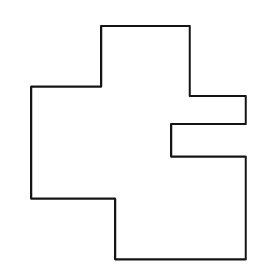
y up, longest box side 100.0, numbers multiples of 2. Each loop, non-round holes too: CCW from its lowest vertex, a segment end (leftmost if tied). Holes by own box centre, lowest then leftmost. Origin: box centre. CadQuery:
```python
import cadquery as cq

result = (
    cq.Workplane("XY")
    .moveTo(-10.0, -50.0)
    .lineTo(46.0, -50.0)
    .lineTo(46.0, -6.0)
    .lineTo(14.0, -6.0)
    .lineTo(14.0, 8.0)
    .lineTo(46.0, 8.0)
    .lineTo(46.0, 20.0)
    .lineTo(22.0, 20.0)
    .lineTo(22.0, 50.0)
    .lineTo(-16.0, 50.0)
    .lineTo(-16.0, 24.0)
    .lineTo(-46.0, 24.0)
    .lineTo(-46.0, -24.0)
    .lineTo(-10.0, -24.0)
    .close()
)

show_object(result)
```